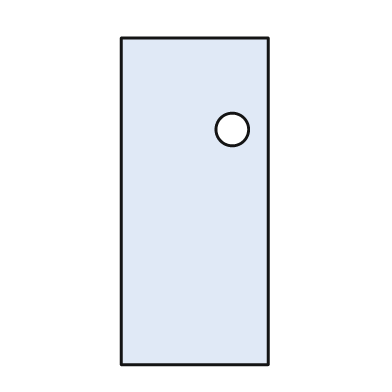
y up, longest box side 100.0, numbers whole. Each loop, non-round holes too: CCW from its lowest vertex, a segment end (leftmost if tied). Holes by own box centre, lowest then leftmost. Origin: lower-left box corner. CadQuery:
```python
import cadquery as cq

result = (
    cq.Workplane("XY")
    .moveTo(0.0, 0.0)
    .lineTo(45.0, 0.0)
    .lineTo(45.0, 100.0)
    .lineTo(0.0, 100.0)
    .close()
    .moveTo(34.0, 72.0)
    .circle(5.0)
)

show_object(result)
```